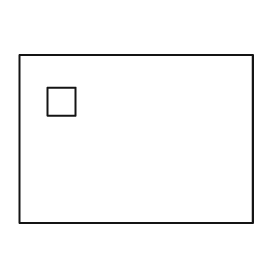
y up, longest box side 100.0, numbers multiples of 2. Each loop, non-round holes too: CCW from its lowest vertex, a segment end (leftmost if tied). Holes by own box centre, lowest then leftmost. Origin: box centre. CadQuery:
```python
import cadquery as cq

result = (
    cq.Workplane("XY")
    .moveTo(-50.0, -36.0)
    .lineTo(50.0, -36.0)
    .lineTo(50.0, 36.0)
    .lineTo(-50.0, 36.0)
    .close()
    .moveTo(-38.0, 10.0)
    .lineTo(-26.0, 10.0)
    .lineTo(-26.0, 22.0)
    .lineTo(-38.0, 22.0)
    .close()
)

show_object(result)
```